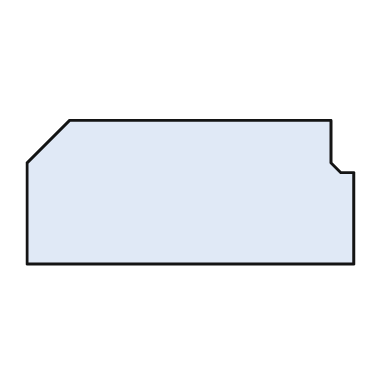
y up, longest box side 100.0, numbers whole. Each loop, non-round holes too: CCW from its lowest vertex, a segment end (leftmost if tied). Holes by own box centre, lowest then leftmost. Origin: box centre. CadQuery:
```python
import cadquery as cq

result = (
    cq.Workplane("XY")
    .moveTo(-50.0, -22.0)
    .lineTo(50.0, -22.0)
    .lineTo(50.0, 6.0)
    .lineTo(46.0, 6.0)
    .lineTo(43.0, 9.0)
    .lineTo(43.0, 22.0)
    .lineTo(-37.0, 22.0)
    .lineTo(-50.0, 9.0)
    .close()
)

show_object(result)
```